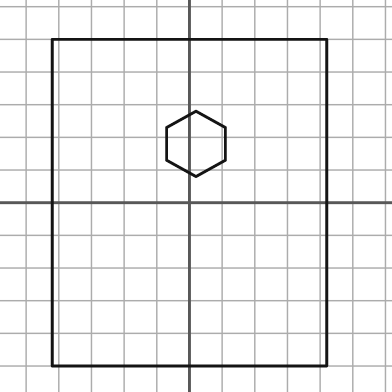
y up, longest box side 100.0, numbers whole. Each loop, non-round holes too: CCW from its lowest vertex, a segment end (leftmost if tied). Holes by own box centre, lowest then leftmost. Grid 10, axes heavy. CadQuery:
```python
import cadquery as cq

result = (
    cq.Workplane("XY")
    .moveTo(-42.0, -50.0)
    .lineTo(42.0, -50.0)
    .lineTo(42.0, 50.0)
    .lineTo(-42.0, 50.0)
    .close()
    .moveTo(2.0, 8.0)
    .lineTo(11.0, 13.0)
    .lineTo(11.0, 23.0)
    .lineTo(2.0, 28.0)
    .lineTo(-7.0, 23.0)
    .lineTo(-7.0, 13.0)
    .close()
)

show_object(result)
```